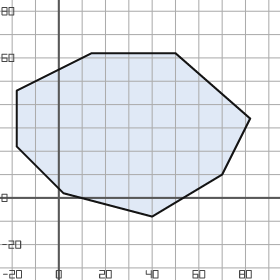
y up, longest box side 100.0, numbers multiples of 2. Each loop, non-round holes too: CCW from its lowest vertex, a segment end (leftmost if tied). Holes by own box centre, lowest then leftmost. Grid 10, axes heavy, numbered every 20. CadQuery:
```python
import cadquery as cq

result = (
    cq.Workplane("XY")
    .moveTo(40.0, -8.0)
    .lineTo(70.0, 10.0)
    .lineTo(82.0, 34.0)
    .lineTo(50.0, 62.0)
    .lineTo(14.0, 62.0)
    .lineTo(-18.0, 46.0)
    .lineTo(-18.0, 22.0)
    .lineTo(2.0, 2.0)
    .close()
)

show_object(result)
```